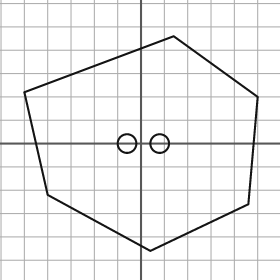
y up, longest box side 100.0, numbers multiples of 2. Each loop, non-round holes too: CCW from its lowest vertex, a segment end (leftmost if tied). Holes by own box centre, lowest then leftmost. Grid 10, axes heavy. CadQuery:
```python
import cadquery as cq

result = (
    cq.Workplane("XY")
    .moveTo(4.0, -46.0)
    .lineTo(46.0, -26.0)
    .lineTo(50.0, 20.0)
    .lineTo(14.0, 46.0)
    .lineTo(-50.0, 22.0)
    .lineTo(-40.0, -22.0)
    .close()
    .moveTo(-6.0, 0.0)
    .circle(4.0)
    .moveTo(8.0, 0.0)
    .circle(4.0)
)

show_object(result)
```